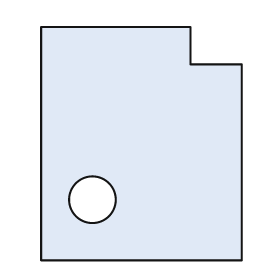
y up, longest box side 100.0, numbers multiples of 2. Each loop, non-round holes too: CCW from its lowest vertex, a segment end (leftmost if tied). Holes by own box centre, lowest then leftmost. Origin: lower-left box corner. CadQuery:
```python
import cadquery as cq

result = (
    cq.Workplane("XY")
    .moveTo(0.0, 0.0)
    .lineTo(86.0, 0.0)
    .lineTo(86.0, 84.0)
    .lineTo(64.0, 84.0)
    .lineTo(64.0, 100.0)
    .lineTo(0.0, 100.0)
    .close()
    .moveTo(22.0, 26.0)
    .circle(10.0)
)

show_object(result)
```